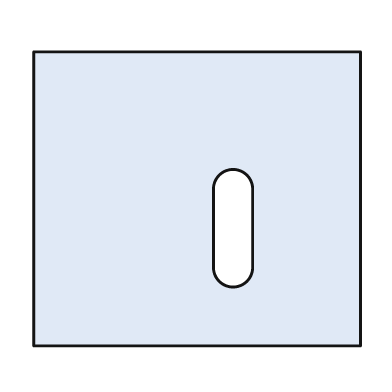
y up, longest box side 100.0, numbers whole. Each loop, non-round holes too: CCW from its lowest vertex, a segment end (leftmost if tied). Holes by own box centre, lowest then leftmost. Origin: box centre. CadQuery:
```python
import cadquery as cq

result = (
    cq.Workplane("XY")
    .moveTo(-50.0, -45.0)
    .lineTo(50.0, -45.0)
    .lineTo(50.0, 45.0)
    .lineTo(-50.0, 45.0)
    .close()
    .moveTo(5.0, -21.0)
    .threePointArc((11.0, -27.0), (17.0, -21.0))
    .lineTo(17.0, 3.0)
    .threePointArc((11.0, 9.0), (5.0, 3.0))
    .close()
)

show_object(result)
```